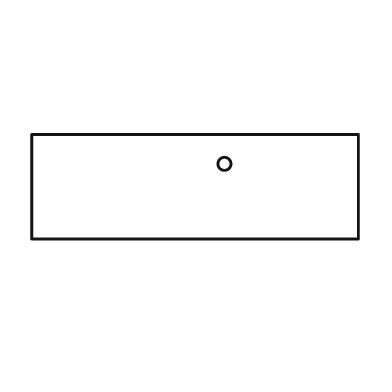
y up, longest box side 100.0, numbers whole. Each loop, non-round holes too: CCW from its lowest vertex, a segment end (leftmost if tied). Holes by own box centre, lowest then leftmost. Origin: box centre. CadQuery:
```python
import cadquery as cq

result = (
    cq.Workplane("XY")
    .moveTo(-50.0, -16.0)
    .lineTo(50.0, -16.0)
    .lineTo(50.0, 16.0)
    .lineTo(-50.0, 16.0)
    .close()
    .moveTo(9.0, 7.0)
    .circle(2.0)
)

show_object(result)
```